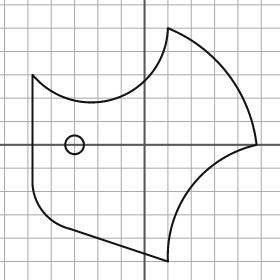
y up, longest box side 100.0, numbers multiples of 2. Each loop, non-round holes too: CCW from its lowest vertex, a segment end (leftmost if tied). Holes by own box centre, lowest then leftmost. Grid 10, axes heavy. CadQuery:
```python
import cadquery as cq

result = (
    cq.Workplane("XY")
    .moveTo(10.0, -50.0)
    .threePointArc((20.0, -18.0), (48.0, 0.0))
    .threePointArc((36.0, 30.0), (10.0, 50.0))
    .threePointArc((-12.0, 20.0), (-48.0, 30.0))
    .lineTo(-48.0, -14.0)
    .threePointArc((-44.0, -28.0), (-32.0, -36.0))
    .close()
    .moveTo(-30.0, 0.0)
    .circle(4.0)
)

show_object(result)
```